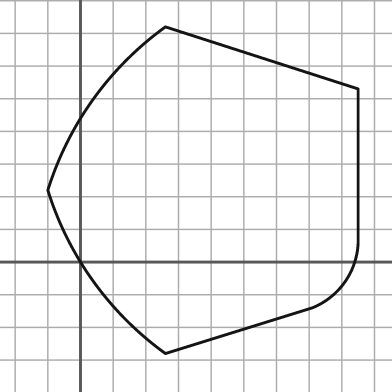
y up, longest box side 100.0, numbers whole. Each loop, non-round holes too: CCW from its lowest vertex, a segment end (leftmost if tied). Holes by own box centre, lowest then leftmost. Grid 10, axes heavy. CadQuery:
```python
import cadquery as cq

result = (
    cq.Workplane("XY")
    .moveTo(26.0, -28.0)
    .lineTo(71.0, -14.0)
    .threePointArc((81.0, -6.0), (85.0, 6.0))
    .lineTo(85.0, 53.0)
    .lineTo(26.0, 72.0)
    .threePointArc((4.0, 50.0), (-10.0, 22.0))
    .threePointArc((4.0, -6.0), (26.0, -28.0))
    .close()
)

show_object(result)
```